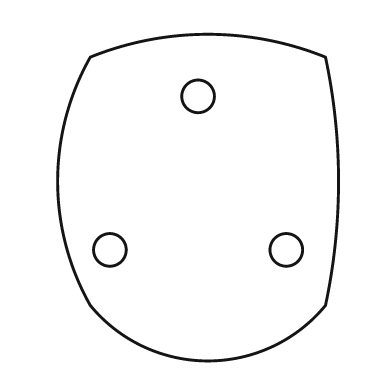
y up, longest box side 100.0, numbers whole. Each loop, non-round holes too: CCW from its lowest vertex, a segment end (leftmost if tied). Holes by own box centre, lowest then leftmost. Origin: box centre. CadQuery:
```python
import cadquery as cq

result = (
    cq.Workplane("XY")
    .moveTo(-33.0, -33.0)
    .threePointArc((3.0, -50.0), (39.0, -33.0))
    .threePointArc((43.0, 5.0), (39.0, 43.0))
    .threePointArc((3.0, 50.0), (-33.0, 43.0))
    .threePointArc((-43.0, 5.0), (-33.0, -33.0))
    .close()
    .moveTo(-27.0, -16.0)
    .circle(5.0)
    .moveTo(27.0, -16.0)
    .circle(5.0)
    .moveTo(0.0, 31.0)
    .circle(5.0)
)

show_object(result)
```